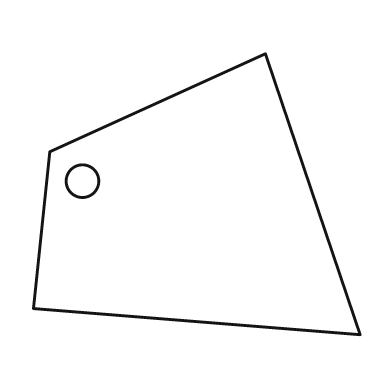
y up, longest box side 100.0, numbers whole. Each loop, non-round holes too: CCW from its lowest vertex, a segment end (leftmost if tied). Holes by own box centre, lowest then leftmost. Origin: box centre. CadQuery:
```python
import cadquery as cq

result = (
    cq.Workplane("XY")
    .moveTo(50.0, -43.0)
    .lineTo(21.0, 43.0)
    .lineTo(-45.0, 13.0)
    .lineTo(-50.0, -35.0)
    .close()
    .moveTo(-35.0, 4.0)
    .circle(5.0)
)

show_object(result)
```